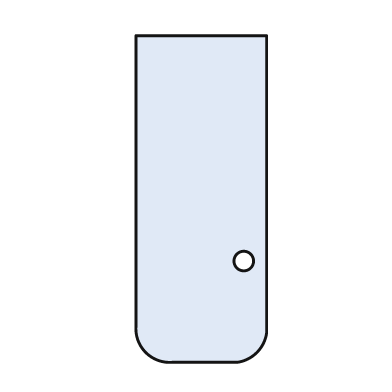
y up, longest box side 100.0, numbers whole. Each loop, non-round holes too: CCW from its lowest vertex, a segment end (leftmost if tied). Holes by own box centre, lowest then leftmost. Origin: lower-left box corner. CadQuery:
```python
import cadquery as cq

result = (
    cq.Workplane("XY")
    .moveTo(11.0, 0.0)
    .lineTo(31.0, 0.0)
    .threePointArc((37.0, 3.0), (40.0, 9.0))
    .lineTo(40.0, 100.0)
    .lineTo(0.0, 100.0)
    .lineTo(0.0, 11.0)
    .threePointArc((3.0, 3.0), (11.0, 0.0))
    .close()
    .moveTo(33.0, 31.0)
    .circle(3.0)
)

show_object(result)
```